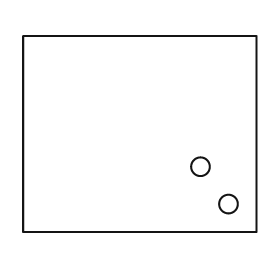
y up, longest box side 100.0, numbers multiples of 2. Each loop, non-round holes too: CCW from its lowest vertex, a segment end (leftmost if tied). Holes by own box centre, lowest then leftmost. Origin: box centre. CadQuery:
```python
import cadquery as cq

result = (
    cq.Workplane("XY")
    .moveTo(-50.0, -42.0)
    .lineTo(50.0, -42.0)
    .lineTo(50.0, 42.0)
    .lineTo(-50.0, 42.0)
    .close()
    .moveTo(38.0, -30.0)
    .circle(4.0)
    .moveTo(26.0, -14.0)
    .circle(4.0)
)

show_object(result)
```